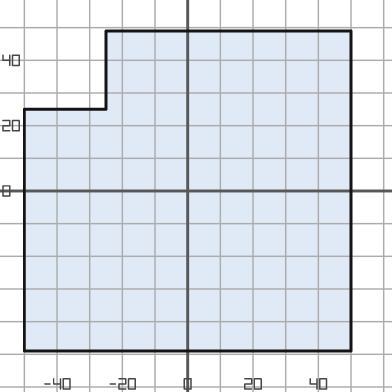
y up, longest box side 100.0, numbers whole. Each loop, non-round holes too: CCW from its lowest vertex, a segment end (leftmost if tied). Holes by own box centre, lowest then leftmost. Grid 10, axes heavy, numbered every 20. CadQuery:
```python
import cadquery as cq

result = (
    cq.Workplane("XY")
    .moveTo(-50.0, -49.0)
    .lineTo(50.0, -49.0)
    .lineTo(50.0, 49.0)
    .lineTo(-25.0, 49.0)
    .lineTo(-25.0, 25.0)
    .lineTo(-50.0, 25.0)
    .close()
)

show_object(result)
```